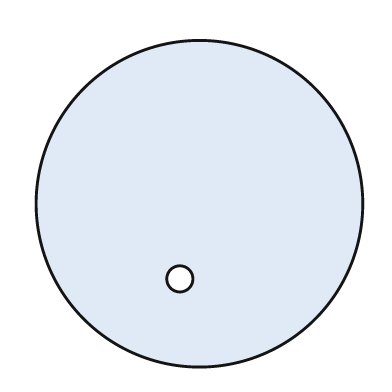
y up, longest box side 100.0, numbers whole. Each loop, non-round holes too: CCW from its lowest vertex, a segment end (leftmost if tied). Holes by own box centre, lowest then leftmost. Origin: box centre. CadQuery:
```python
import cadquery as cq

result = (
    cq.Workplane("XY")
    .moveTo(0.0, 0.0)
    .circle(50.0)
    .moveTo(-6.0, -23.0)
    .circle(4.0)
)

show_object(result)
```